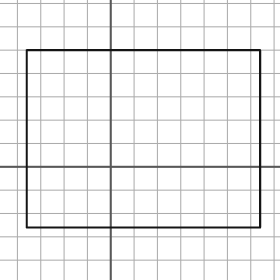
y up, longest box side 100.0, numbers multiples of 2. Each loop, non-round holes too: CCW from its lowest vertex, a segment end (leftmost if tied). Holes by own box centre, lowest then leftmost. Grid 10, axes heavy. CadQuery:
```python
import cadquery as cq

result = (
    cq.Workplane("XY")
    .moveTo(-36.0, -26.0)
    .lineTo(64.0, -26.0)
    .lineTo(64.0, 50.0)
    .lineTo(-36.0, 50.0)
    .close()
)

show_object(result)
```